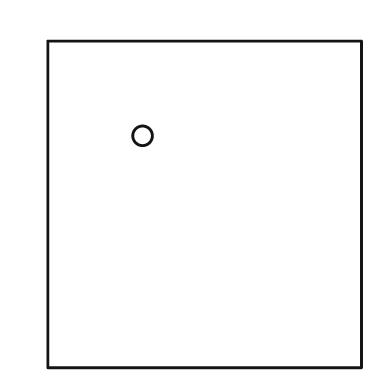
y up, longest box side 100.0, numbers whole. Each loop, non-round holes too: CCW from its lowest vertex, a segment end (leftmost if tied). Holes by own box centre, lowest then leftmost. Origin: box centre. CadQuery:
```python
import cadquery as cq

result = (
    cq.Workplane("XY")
    .moveTo(-48.0, -50.0)
    .lineTo(48.0, -50.0)
    .lineTo(48.0, 50.0)
    .lineTo(-48.0, 50.0)
    .close()
    .moveTo(-19.0, 21.0)
    .circle(3.0)
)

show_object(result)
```